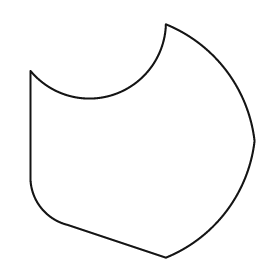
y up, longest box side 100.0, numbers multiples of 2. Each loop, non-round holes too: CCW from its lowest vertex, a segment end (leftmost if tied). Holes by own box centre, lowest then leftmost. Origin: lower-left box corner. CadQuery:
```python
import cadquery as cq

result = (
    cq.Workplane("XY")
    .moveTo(58.0, 0.0)
    .threePointArc((84.0, 20.0), (96.0, 50.0))
    .threePointArc((84.0, 80.0), (58.0, 100.0))
    .threePointArc((36.0, 70.0), (0.0, 80.0))
    .lineTo(0.0, 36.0)
    .threePointArc((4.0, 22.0), (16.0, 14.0))
    .close()
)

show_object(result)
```